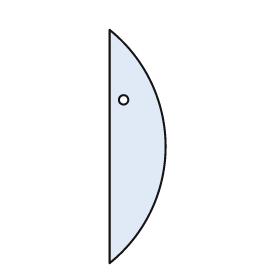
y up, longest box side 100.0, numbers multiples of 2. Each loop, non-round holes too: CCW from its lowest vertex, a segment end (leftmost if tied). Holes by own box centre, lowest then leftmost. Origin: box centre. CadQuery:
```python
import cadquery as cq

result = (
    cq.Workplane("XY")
    .moveTo(-12.0, -50.0)
    .threePointArc((12.0, 0.0), (-12.0, 50.0))
    .close()
    .moveTo(-6.0, 20.0)
    .circle(2.0)
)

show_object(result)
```